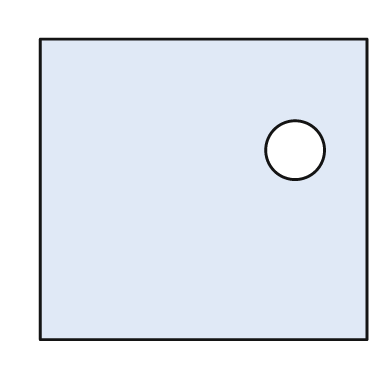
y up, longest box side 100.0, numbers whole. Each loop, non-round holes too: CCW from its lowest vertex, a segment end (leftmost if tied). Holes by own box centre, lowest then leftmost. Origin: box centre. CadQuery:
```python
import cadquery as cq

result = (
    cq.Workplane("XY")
    .moveTo(-50.0, -46.0)
    .lineTo(50.0, -46.0)
    .lineTo(50.0, 46.0)
    .lineTo(-50.0, 46.0)
    .close()
    .moveTo(28.0, 12.0)
    .circle(9.0)
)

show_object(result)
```